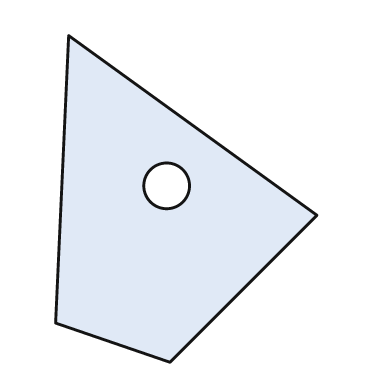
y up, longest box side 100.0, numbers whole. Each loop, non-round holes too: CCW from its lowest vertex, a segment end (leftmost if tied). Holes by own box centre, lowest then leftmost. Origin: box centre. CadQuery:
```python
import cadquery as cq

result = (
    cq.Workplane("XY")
    .moveTo(-5.0, -50.0)
    .lineTo(40.0, -5.0)
    .lineTo(-36.0, 50.0)
    .lineTo(-40.0, -38.0)
    .close()
    .moveTo(-6.0, 4.0)
    .circle(7.0)
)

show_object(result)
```